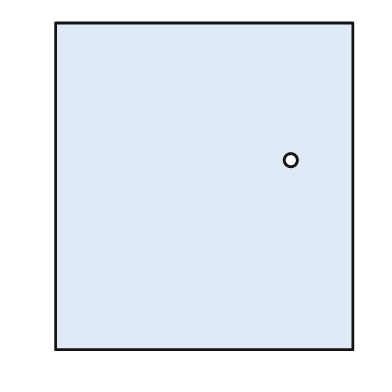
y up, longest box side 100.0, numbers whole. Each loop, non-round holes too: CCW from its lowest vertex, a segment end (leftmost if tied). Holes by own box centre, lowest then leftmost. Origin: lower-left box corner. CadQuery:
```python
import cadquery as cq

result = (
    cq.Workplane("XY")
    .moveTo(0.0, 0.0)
    .lineTo(91.0, 0.0)
    .lineTo(91.0, 100.0)
    .lineTo(0.0, 100.0)
    .close()
    .moveTo(72.0, 58.0)
    .circle(2.0)
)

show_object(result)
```